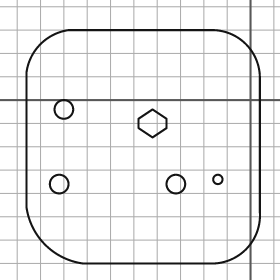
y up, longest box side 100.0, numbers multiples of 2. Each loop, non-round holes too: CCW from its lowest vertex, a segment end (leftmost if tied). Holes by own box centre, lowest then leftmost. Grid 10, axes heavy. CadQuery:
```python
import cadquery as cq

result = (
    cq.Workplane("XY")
    .moveTo(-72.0, -70.0)
    .lineTo(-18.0, -70.0)
    .threePointArc((-2.0, -64.0), (4.0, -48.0))
    .lineTo(4.0, 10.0)
    .threePointArc((-2.0, 24.0), (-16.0, 30.0))
    .lineTo(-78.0, 30.0)
    .threePointArc((-90.0, 24.0), (-96.0, 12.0))
    .lineTo(-96.0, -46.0)
    .threePointArc((-88.0, -62.0), (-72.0, -70.0))
    .close()
    .moveTo(-82.0, -36.0)
    .circle(4.0)
    .moveTo(-32.0, -36.0)
    .circle(4.0)
    .moveTo(-14.0, -34.0)
    .circle(2.0)
    .moveTo(-42.0, -16.0)
    .lineTo(-36.0, -12.0)
    .lineTo(-36.0, -8.0)
    .lineTo(-42.0, -4.0)
    .lineTo(-48.0, -8.0)
    .lineTo(-48.0, -12.0)
    .close()
    .moveTo(-80.0, -4.0)
    .circle(4.0)
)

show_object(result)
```